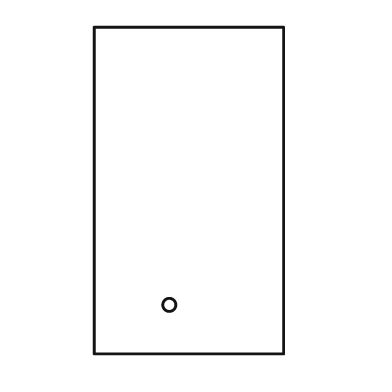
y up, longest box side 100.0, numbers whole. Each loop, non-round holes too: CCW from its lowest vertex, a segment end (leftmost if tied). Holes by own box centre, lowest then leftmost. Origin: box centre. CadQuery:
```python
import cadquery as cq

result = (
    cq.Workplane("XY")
    .moveTo(-29.0, -50.0)
    .lineTo(29.0, -50.0)
    .lineTo(29.0, 50.0)
    .lineTo(-29.0, 50.0)
    .close()
    .moveTo(-6.0, -35.0)
    .circle(2.0)
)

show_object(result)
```